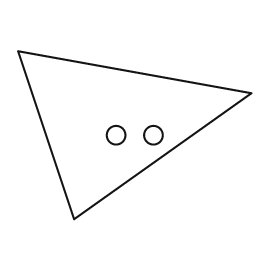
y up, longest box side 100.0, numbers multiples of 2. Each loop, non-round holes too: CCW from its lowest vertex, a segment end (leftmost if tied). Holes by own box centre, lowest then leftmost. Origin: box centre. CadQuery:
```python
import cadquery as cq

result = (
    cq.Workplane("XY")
    .moveTo(-26.0, -36.0)
    .lineTo(50.0, 18.0)
    .lineTo(-50.0, 36.0)
    .close()
    .moveTo(-8.0, 0.0)
    .circle(4.0)
    .moveTo(8.0, 0.0)
    .circle(4.0)
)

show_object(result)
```